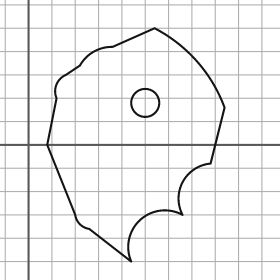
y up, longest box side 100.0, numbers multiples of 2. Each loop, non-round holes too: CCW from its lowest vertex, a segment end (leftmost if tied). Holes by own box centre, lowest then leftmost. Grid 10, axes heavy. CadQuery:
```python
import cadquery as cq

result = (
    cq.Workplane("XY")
    .moveTo(44.0, -50.0)
    .threePointArc((48.0, -32.0), (66.0, -30.0))
    .threePointArc((66.0, -16.0), (78.0, -8.0))
    .lineTo(84.0, 16.0)
    .threePointArc((72.0, 36.0), (54.0, 50.0))
    .lineTo(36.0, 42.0)
    .threePointArc((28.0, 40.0), (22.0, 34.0))
    .lineTo(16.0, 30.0)
    .threePointArc((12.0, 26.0), (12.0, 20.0))
    .lineTo(8.0, 0.0)
    .lineTo(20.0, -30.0)
    .threePointArc((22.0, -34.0), (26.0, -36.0))
    .close()
    .moveTo(50.0, 18.0)
    .circle(6.0)
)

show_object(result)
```